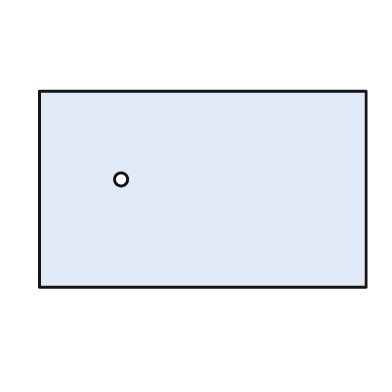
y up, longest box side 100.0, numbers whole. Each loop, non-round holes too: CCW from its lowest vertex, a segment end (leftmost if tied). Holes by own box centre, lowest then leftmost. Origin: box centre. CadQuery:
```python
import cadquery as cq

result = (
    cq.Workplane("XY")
    .moveTo(-50.0, -30.0)
    .lineTo(50.0, -30.0)
    .lineTo(50.0, 30.0)
    .lineTo(-50.0, 30.0)
    .close()
    .moveTo(-25.0, 3.0)
    .circle(2.0)
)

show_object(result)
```